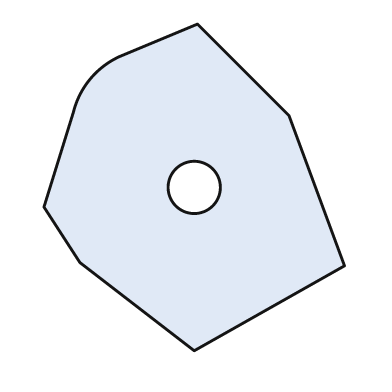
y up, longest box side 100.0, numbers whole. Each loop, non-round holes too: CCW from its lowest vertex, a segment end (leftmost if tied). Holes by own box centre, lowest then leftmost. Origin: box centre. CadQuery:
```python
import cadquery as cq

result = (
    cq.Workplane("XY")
    .moveTo(0.0, -50.0)
    .lineTo(46.0, -24.0)
    .lineTo(29.0, 22.0)
    .lineTo(1.0, 50.0)
    .lineTo(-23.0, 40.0)
    .threePointArc((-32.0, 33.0), (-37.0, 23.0))
    .lineTo(-46.0, -6.0)
    .lineTo(-35.0, -23.0)
    .close()
    .moveTo(0.0, 0.0)
    .circle(8.0)
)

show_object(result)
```